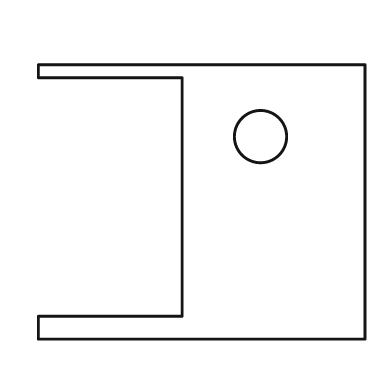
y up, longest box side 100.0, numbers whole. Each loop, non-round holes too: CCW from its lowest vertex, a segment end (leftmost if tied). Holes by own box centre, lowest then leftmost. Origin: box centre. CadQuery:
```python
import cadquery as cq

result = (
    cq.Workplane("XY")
    .moveTo(-50.0, -42.0)
    .lineTo(50.0, -42.0)
    .lineTo(50.0, 42.0)
    .lineTo(-50.0, 42.0)
    .lineTo(-50.0, 38.0)
    .lineTo(-6.0, 38.0)
    .lineTo(-6.0, -35.0)
    .lineTo(-50.0, -35.0)
    .close()
    .moveTo(18.0, 20.0)
    .circle(8.0)
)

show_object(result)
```